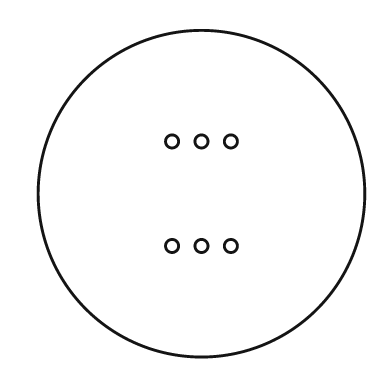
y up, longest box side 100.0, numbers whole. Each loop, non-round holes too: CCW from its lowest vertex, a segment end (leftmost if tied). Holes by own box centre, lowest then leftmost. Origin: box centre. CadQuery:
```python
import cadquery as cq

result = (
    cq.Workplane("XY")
    .moveTo(0.0, 0.0)
    .circle(50.0)
    .moveTo(-9.0, -16.0)
    .circle(2.0)
    .moveTo(0.0, -16.0)
    .circle(2.0)
    .moveTo(9.0, -16.0)
    .circle(2.0)
    .moveTo(-9.0, 16.0)
    .circle(2.0)
    .moveTo(0.0, 16.0)
    .circle(2.0)
    .moveTo(9.0, 16.0)
    .circle(2.0)
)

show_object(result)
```